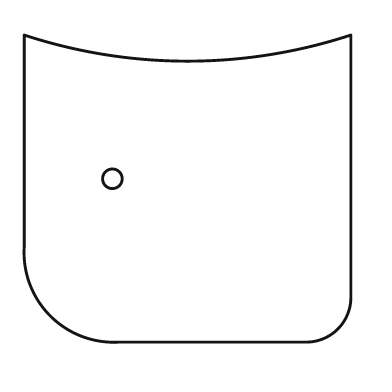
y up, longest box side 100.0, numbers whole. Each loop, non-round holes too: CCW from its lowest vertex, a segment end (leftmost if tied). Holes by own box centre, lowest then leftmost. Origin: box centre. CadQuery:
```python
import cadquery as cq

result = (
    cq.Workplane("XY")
    .moveTo(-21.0, -47.0)
    .lineTo(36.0, -47.0)
    .threePointArc((46.0, -43.0), (50.0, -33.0))
    .lineTo(50.0, 47.0)
    .threePointArc((0.0, 39.0), (-50.0, 47.0))
    .lineTo(-50.0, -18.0)
    .threePointArc((-42.0, -39.0), (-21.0, -47.0))
    .close()
    .moveTo(-23.0, 3.0)
    .circle(3.0)
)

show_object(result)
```